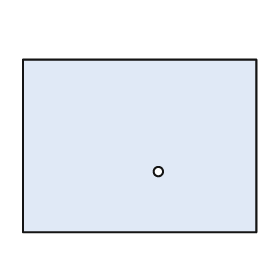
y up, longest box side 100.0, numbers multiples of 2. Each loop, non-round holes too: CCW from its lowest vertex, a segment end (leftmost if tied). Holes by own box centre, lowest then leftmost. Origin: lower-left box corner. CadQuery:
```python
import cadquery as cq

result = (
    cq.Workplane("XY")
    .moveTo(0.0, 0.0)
    .lineTo(100.0, 0.0)
    .lineTo(100.0, 74.0)
    .lineTo(0.0, 74.0)
    .close()
    .moveTo(58.0, 26.0)
    .circle(2.0)
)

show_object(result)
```